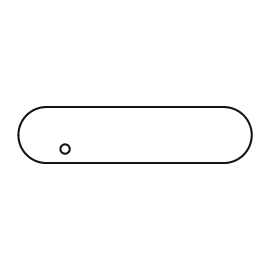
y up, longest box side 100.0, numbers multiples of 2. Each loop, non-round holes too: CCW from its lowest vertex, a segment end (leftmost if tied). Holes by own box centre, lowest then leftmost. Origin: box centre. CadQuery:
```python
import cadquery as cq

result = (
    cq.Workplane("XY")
    .moveTo(-38.0, -12.0)
    .lineTo(38.0, -12.0)
    .threePointArc((50.0, 0.0), (38.0, 12.0))
    .lineTo(-38.0, 12.0)
    .threePointArc((-50.0, 0.0), (-38.0, -12.0))
    .close()
    .moveTo(-30.0, -6.0)
    .circle(2.0)
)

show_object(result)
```